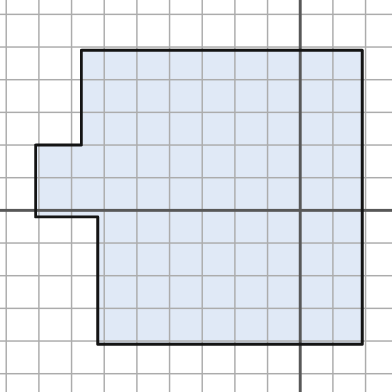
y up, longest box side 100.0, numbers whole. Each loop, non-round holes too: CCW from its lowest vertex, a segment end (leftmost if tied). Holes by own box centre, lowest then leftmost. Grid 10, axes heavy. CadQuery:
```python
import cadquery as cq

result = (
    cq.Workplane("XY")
    .moveTo(-62.0, -41.0)
    .lineTo(19.0, -41.0)
    .lineTo(19.0, 49.0)
    .lineTo(-67.0, 49.0)
    .lineTo(-67.0, 20.0)
    .lineTo(-81.0, 20.0)
    .lineTo(-81.0, -2.0)
    .lineTo(-62.0, -2.0)
    .close()
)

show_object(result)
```